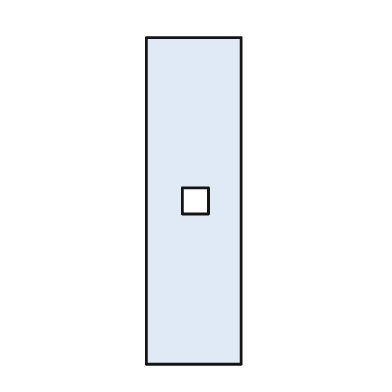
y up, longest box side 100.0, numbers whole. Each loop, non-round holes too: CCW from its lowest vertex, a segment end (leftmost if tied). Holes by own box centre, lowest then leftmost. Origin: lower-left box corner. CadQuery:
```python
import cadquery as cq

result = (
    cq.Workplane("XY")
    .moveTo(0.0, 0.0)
    .lineTo(29.0, 0.0)
    .lineTo(29.0, 100.0)
    .lineTo(0.0, 100.0)
    .close()
    .moveTo(11.0, 46.0)
    .lineTo(19.0, 46.0)
    .lineTo(19.0, 54.0)
    .lineTo(11.0, 54.0)
    .close()
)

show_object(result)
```